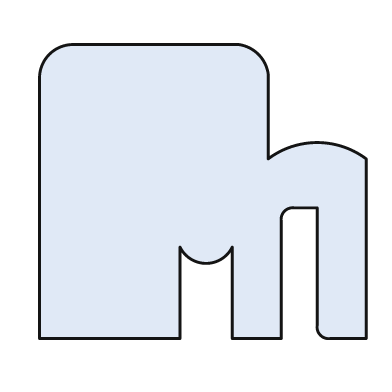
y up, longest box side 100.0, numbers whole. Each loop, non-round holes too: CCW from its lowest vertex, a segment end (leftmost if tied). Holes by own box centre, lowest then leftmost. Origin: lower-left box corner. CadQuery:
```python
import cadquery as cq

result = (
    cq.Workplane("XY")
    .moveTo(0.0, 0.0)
    .lineTo(43.0, 0.0)
    .lineTo(43.0, 28.0)
    .threePointArc((51.0, 23.0), (59.0, 28.0))
    .lineTo(59.0, 0.0)
    .lineTo(74.0, 0.0)
    .lineTo(74.0, 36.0)
    .threePointArc((75.0, 39.0), (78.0, 40.0))
    .lineTo(85.0, 40.0)
    .lineTo(85.0, 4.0)
    .threePointArc((86.0, 1.0), (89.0, 0.0))
    .lineTo(100.0, 0.0)
    .lineTo(100.0, 55.0)
    .threePointArc((85.0, 60.0), (70.0, 55.0))
    .lineTo(70.0, 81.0)
    .threePointArc((67.0, 87.0), (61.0, 90.0))
    .lineTo(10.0, 90.0)
    .threePointArc((3.0, 87.0), (0.0, 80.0))
    .close()
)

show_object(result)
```